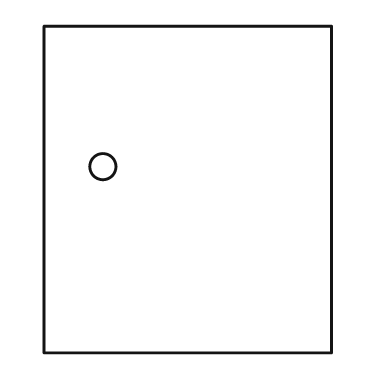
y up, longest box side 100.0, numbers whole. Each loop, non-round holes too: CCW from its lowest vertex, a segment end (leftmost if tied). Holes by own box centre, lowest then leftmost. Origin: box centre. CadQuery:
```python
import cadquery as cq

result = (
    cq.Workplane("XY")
    .moveTo(-44.0, -50.0)
    .lineTo(44.0, -50.0)
    .lineTo(44.0, 50.0)
    .lineTo(-44.0, 50.0)
    .close()
    .moveTo(-26.0, 7.0)
    .circle(4.0)
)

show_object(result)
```